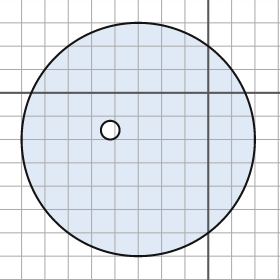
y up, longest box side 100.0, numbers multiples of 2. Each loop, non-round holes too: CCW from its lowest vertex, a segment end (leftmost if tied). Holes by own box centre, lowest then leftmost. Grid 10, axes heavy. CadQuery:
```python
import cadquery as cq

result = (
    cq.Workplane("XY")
    .moveTo(-30.0, -20.0)
    .circle(50.0)
    .moveTo(-42.0, -16.0)
    .circle(4.0)
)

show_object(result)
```